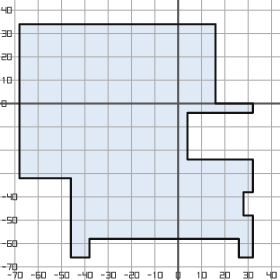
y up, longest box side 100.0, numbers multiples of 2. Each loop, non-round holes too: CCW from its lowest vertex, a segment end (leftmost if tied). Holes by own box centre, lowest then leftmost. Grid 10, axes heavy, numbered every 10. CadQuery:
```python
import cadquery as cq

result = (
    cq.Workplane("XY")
    .moveTo(-46.0, -66.0)
    .lineTo(-38.0, -66.0)
    .lineTo(-38.0, -58.0)
    .lineTo(26.0, -58.0)
    .lineTo(26.0, -66.0)
    .lineTo(32.0, -66.0)
    .lineTo(32.0, -48.0)
    .lineTo(28.0, -48.0)
    .lineTo(28.0, -38.0)
    .lineTo(32.0, -38.0)
    .lineTo(32.0, -24.0)
    .lineTo(4.0, -24.0)
    .lineTo(4.0, -4.0)
    .lineTo(32.0, -4.0)
    .lineTo(32.0, 0.0)
    .lineTo(16.0, 0.0)
    .lineTo(16.0, 34.0)
    .lineTo(-68.0, 34.0)
    .lineTo(-68.0, -32.0)
    .lineTo(-46.0, -32.0)
    .close()
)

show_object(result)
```